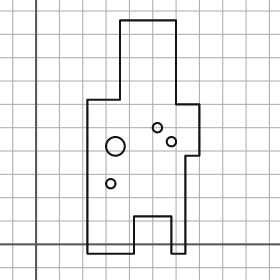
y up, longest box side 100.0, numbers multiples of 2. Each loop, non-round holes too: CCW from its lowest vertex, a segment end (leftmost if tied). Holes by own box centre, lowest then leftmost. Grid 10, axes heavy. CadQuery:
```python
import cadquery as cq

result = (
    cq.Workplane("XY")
    .moveTo(22.0, -4.0)
    .lineTo(42.0, -4.0)
    .lineTo(42.0, 12.0)
    .lineTo(58.0, 12.0)
    .lineTo(58.0, -4.0)
    .lineTo(64.0, -4.0)
    .lineTo(64.0, 38.0)
    .lineTo(70.0, 38.0)
    .lineTo(70.0, 60.0)
    .lineTo(60.0, 60.0)
    .lineTo(60.0, 96.0)
    .lineTo(36.0, 96.0)
    .lineTo(36.0, 62.0)
    .lineTo(22.0, 62.0)
    .close()
    .moveTo(32.0, 26.0)
    .circle(2.0)
    .moveTo(34.0, 42.0)
    .circle(4.0)
    .moveTo(58.0, 44.0)
    .circle(2.0)
    .moveTo(52.0, 50.0)
    .circle(2.0)
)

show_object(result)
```